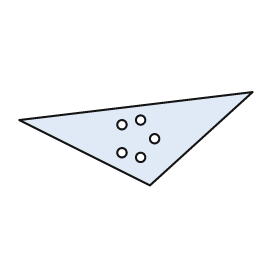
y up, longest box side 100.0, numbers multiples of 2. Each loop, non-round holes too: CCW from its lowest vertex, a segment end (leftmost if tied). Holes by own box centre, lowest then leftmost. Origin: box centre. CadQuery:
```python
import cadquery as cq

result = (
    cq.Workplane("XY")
    .moveTo(6.0, -20.0)
    .lineTo(50.0, 20.0)
    .lineTo(-50.0, 8.0)
    .close()
    .moveTo(2.0, -8.0)
    .circle(2.0)
    .moveTo(-6.0, -6.0)
    .circle(2.0)
    .moveTo(8.0, 0.0)
    .circle(2.0)
    .moveTo(-6.0, 6.0)
    .circle(2.0)
    .moveTo(2.0, 8.0)
    .circle(2.0)
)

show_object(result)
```